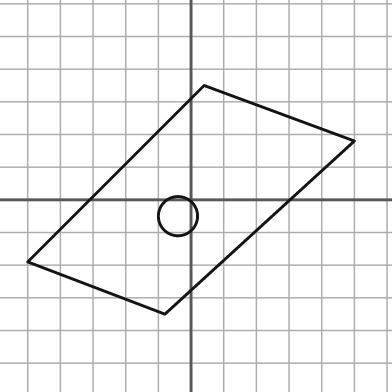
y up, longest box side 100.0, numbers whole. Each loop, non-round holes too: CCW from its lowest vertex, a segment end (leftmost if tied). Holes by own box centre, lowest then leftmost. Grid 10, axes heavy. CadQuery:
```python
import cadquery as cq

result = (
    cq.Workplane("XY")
    .moveTo(-8.0, -35.0)
    .lineTo(50.0, 18.0)
    .lineTo(4.0, 35.0)
    .lineTo(-50.0, -19.0)
    .close()
    .moveTo(-4.0, -5.0)
    .circle(6.0)
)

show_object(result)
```